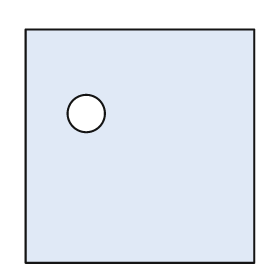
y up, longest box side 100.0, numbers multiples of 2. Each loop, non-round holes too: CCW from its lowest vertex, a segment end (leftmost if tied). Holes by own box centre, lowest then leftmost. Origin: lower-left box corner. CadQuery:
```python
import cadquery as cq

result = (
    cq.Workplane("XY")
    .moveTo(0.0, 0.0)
    .lineTo(98.0, 0.0)
    .lineTo(98.0, 100.0)
    .lineTo(0.0, 100.0)
    .close()
    .moveTo(26.0, 64.0)
    .circle(8.0)
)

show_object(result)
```